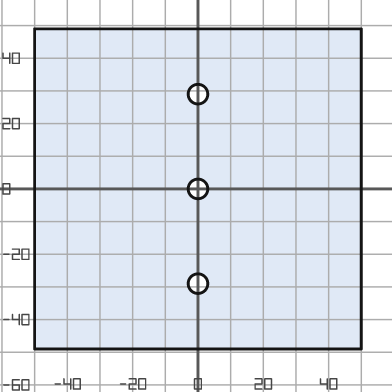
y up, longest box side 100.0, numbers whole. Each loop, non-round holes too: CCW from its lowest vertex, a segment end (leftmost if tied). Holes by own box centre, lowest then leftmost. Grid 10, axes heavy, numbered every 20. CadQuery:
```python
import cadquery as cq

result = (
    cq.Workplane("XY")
    .moveTo(-50.0, -49.0)
    .lineTo(50.0, -49.0)
    .lineTo(50.0, 49.0)
    .lineTo(-50.0, 49.0)
    .close()
    .moveTo(0.0, -29.0)
    .circle(3.0)
    .moveTo(0.0, 0.0)
    .circle(3.0)
    .moveTo(0.0, 29.0)
    .circle(3.0)
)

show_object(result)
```